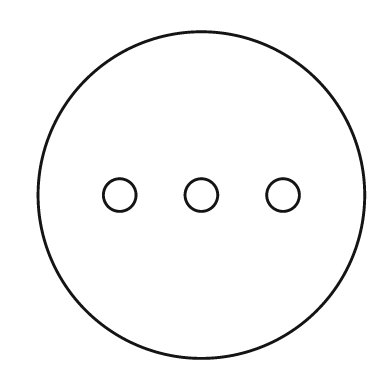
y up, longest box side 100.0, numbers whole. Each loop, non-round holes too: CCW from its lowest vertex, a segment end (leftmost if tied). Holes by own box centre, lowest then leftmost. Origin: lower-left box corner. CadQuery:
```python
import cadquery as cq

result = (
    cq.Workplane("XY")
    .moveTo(50.0, 50.0)
    .circle(50.0)
    .moveTo(25.0, 50.0)
    .circle(5.0)
    .moveTo(50.0, 50.0)
    .circle(5.0)
    .moveTo(75.0, 50.0)
    .circle(5.0)
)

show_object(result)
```